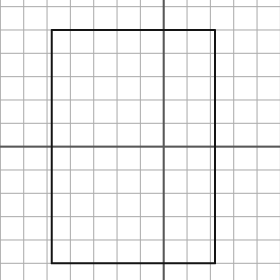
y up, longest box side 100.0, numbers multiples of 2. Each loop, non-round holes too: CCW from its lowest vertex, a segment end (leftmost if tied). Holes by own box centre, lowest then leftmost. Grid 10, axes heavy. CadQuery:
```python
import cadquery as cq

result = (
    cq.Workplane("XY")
    .moveTo(-48.0, -50.0)
    .lineTo(22.0, -50.0)
    .lineTo(22.0, 50.0)
    .lineTo(-48.0, 50.0)
    .close()
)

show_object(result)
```